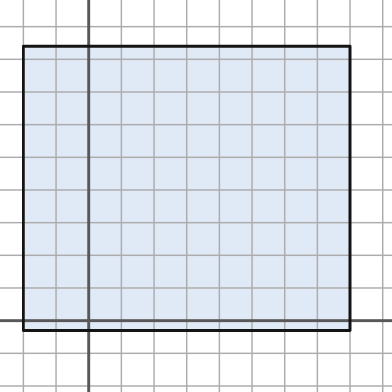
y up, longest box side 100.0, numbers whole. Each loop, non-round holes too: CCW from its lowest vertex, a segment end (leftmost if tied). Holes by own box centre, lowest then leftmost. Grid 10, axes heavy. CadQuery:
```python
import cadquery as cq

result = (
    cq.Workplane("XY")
    .moveTo(-20.0, -3.0)
    .lineTo(80.0, -3.0)
    .lineTo(80.0, 84.0)
    .lineTo(-20.0, 84.0)
    .close()
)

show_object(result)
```